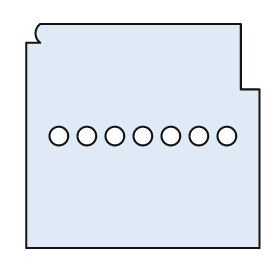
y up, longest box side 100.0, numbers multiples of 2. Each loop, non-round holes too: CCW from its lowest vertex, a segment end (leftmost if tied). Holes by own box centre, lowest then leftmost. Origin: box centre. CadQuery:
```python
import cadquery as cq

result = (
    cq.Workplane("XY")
    .moveTo(-50.0, -48.0)
    .lineTo(50.0, -48.0)
    .lineTo(50.0, 20.0)
    .lineTo(42.0, 20.0)
    .lineTo(42.0, 48.0)
    .lineTo(-44.0, 48.0)
    .threePointArc((-46.0, 44.0), (-44.0, 40.0))
    .lineTo(-50.0, 40.0)
    .close()
    .moveTo(-36.0, 0.0)
    .circle(4.0)
    .moveTo(-24.0, 0.0)
    .circle(4.0)
    .moveTo(-12.0, 0.0)
    .circle(4.0)
    .moveTo(0.0, 0.0)
    .circle(4.0)
    .moveTo(12.0, 0.0)
    .circle(4.0)
    .moveTo(24.0, 0.0)
    .circle(4.0)
    .moveTo(36.0, 0.0)
    .circle(4.0)
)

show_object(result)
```